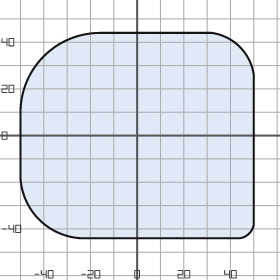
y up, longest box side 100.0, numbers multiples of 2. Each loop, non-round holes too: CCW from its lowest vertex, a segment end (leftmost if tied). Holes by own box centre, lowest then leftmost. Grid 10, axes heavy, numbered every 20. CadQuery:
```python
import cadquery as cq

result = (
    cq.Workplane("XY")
    .moveTo(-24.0, -44.0)
    .lineTo(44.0, -44.0)
    .threePointArc((48.0, -42.0), (50.0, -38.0))
    .lineTo(50.0, 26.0)
    .threePointArc((44.0, 38.0), (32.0, 44.0))
    .lineTo(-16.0, 44.0)
    .threePointArc((-40.0, 34.0), (-50.0, 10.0))
    .lineTo(-50.0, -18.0)
    .threePointArc((-42.0, -36.0), (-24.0, -44.0))
    .close()
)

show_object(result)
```